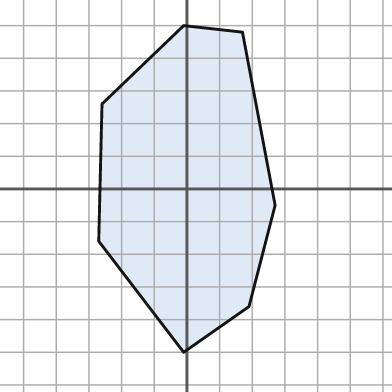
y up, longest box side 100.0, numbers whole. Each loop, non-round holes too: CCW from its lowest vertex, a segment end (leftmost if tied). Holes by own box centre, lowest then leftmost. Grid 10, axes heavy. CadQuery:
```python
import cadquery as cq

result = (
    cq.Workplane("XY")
    .moveTo(-1.0, -50.0)
    .lineTo(19.0, -36.0)
    .lineTo(27.0, -5.0)
    .lineTo(17.0, 48.0)
    .lineTo(-1.0, 50.0)
    .lineTo(-26.0, 26.0)
    .lineTo(-27.0, -16.0)
    .close()
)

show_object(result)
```